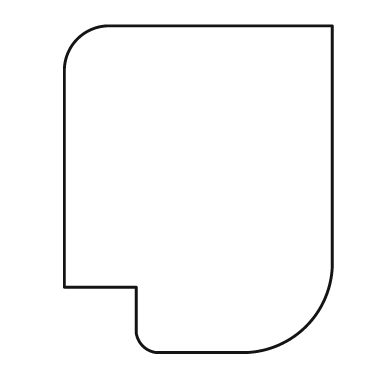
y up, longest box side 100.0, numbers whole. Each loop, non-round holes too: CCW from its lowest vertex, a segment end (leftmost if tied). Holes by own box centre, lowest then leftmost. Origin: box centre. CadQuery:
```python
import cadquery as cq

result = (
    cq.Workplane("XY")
    .moveTo(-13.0, -50.0)
    .lineTo(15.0, -50.0)
    .threePointArc((33.0, -42.0), (41.0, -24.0))
    .lineTo(41.0, 50.0)
    .lineTo(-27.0, 50.0)
    .threePointArc((-37.0, 46.0), (-41.0, 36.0))
    .lineTo(-41.0, -30.0)
    .lineTo(-19.0, -30.0)
    .lineTo(-19.0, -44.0)
    .threePointArc((-17.0, -48.0), (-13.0, -50.0))
    .close()
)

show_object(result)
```